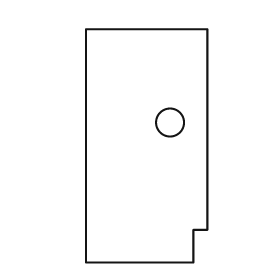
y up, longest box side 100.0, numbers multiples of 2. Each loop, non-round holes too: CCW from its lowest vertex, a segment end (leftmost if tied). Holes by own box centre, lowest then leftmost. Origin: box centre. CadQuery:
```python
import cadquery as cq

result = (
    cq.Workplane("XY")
    .moveTo(-26.0, -50.0)
    .lineTo(20.0, -50.0)
    .lineTo(20.0, -36.0)
    .lineTo(26.0, -36.0)
    .lineTo(26.0, 50.0)
    .lineTo(-26.0, 50.0)
    .close()
    .moveTo(10.0, 10.0)
    .circle(6.0)
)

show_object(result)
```